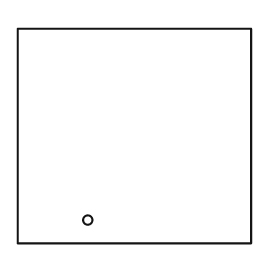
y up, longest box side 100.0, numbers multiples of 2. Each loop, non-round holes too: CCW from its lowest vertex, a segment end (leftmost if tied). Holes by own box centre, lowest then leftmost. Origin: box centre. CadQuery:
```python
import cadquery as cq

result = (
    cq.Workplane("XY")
    .moveTo(-50.0, -46.0)
    .lineTo(50.0, -46.0)
    .lineTo(50.0, 46.0)
    .lineTo(-50.0, 46.0)
    .close()
    .moveTo(-20.0, -36.0)
    .circle(2.0)
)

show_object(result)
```